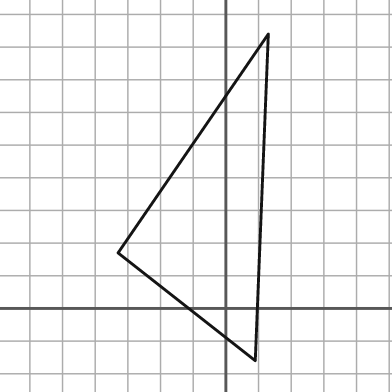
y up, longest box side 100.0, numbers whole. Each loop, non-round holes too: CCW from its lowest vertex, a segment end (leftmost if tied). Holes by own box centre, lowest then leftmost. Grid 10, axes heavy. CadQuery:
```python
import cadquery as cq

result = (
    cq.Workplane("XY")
    .moveTo(9.0, -16.0)
    .lineTo(13.0, 84.0)
    .lineTo(-33.0, 17.0)
    .close()
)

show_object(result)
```